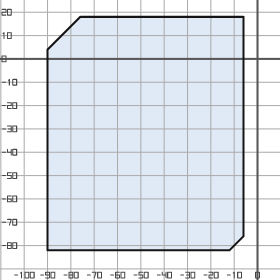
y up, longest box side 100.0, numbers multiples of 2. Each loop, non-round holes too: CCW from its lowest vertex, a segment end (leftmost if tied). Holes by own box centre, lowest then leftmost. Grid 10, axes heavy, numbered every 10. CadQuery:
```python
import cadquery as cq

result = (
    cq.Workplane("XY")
    .moveTo(-90.0, -82.0)
    .lineTo(-12.0, -82.0)
    .lineTo(-6.0, -76.0)
    .lineTo(-6.0, 18.0)
    .lineTo(-76.0, 18.0)
    .lineTo(-90.0, 4.0)
    .close()
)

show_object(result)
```